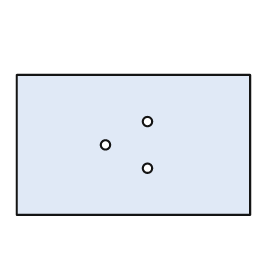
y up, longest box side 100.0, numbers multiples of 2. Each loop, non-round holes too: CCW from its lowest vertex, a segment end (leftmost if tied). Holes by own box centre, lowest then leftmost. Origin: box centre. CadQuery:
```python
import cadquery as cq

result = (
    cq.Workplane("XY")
    .moveTo(-50.0, -30.0)
    .lineTo(50.0, -30.0)
    .lineTo(50.0, 30.0)
    .lineTo(-50.0, 30.0)
    .close()
    .moveTo(6.0, -10.0)
    .circle(2.0)
    .moveTo(-12.0, 0.0)
    .circle(2.0)
    .moveTo(6.0, 10.0)
    .circle(2.0)
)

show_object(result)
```